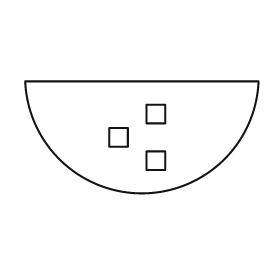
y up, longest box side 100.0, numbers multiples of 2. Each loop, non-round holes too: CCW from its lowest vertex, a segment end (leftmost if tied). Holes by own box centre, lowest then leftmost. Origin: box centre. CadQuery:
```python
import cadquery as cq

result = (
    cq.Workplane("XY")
    .moveTo(-50.0, 24.0)
    .threePointArc((0.0, -24.0), (50.0, 24.0))
    .close()
    .moveTo(2.0, -14.0)
    .lineTo(10.0, -14.0)
    .lineTo(10.0, -6.0)
    .lineTo(2.0, -6.0)
    .close()
    .moveTo(-14.0, -4.0)
    .lineTo(-6.0, -4.0)
    .lineTo(-6.0, 4.0)
    .lineTo(-14.0, 4.0)
    .close()
    .moveTo(2.0, 6.0)
    .lineTo(10.0, 6.0)
    .lineTo(10.0, 14.0)
    .lineTo(2.0, 14.0)
    .close()
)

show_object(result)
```